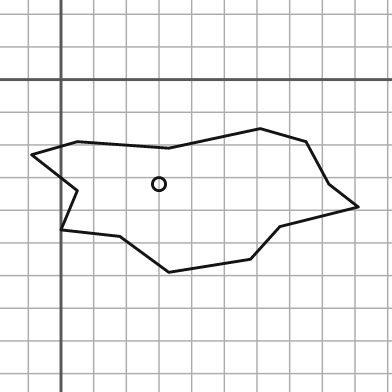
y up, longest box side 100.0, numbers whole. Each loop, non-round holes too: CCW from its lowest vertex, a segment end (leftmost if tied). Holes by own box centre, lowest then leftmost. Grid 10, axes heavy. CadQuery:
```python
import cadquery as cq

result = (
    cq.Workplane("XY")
    .moveTo(33.0, -59.0)
    .lineTo(58.0, -55.0)
    .lineTo(67.0, -45.0)
    .lineTo(91.0, -39.0)
    .lineTo(82.0, -32.0)
    .lineTo(75.0, -19.0)
    .lineTo(61.0, -15.0)
    .lineTo(33.0, -21.0)
    .lineTo(5.0, -19.0)
    .lineTo(-9.0, -23.0)
    .lineTo(5.0, -34.0)
    .lineTo(0.0, -46.0)
    .lineTo(18.0, -48.0)
    .close()
    .moveTo(30.0, -32.0)
    .circle(2.0)
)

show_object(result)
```